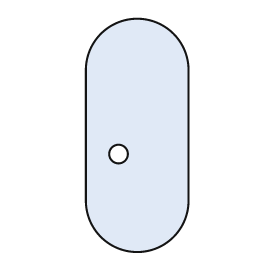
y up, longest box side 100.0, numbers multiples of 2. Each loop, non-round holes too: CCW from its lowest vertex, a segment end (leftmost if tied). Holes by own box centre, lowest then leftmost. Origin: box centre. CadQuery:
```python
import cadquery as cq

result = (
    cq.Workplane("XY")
    .moveTo(-22.0, -28.0)
    .threePointArc((0.0, -50.0), (22.0, -28.0))
    .lineTo(22.0, 28.0)
    .threePointArc((0.0, 50.0), (-22.0, 28.0))
    .close()
    .moveTo(-8.0, -8.0)
    .circle(4.0)
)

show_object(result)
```